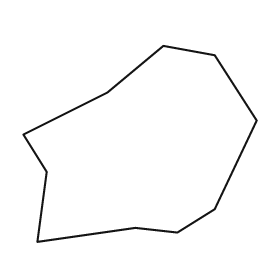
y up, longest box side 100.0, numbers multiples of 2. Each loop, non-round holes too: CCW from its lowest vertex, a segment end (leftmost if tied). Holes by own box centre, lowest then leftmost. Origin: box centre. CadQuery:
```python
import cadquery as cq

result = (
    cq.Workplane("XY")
    .moveTo(-44.0, -42.0)
    .lineTo(-2.0, -36.0)
    .lineTo(16.0, -38.0)
    .lineTo(32.0, -28.0)
    .lineTo(50.0, 10.0)
    .lineTo(32.0, 38.0)
    .lineTo(10.0, 42.0)
    .lineTo(-14.0, 22.0)
    .lineTo(-50.0, 4.0)
    .lineTo(-40.0, -12.0)
    .close()
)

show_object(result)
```